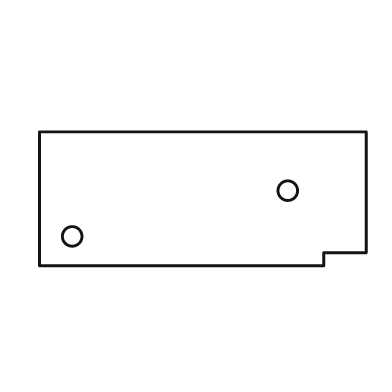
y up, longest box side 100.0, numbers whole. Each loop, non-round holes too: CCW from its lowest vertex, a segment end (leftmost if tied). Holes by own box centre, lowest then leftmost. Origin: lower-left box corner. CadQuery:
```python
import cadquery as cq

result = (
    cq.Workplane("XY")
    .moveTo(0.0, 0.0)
    .lineTo(87.0, 0.0)
    .lineTo(87.0, 4.0)
    .lineTo(100.0, 4.0)
    .lineTo(100.0, 41.0)
    .lineTo(0.0, 41.0)
    .close()
    .moveTo(10.0, 9.0)
    .circle(3.0)
    .moveTo(76.0, 23.0)
    .circle(3.0)
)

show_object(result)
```